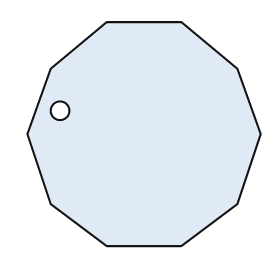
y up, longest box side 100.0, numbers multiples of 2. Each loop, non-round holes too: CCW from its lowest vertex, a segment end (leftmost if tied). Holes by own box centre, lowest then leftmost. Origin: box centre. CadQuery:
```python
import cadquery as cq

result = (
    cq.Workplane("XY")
    .moveTo(-16.0, -48.0)
    .lineTo(16.0, -48.0)
    .lineTo(40.0, -30.0)
    .lineTo(50.0, 0.0)
    .lineTo(40.0, 28.0)
    .lineTo(16.0, 48.0)
    .lineTo(-16.0, 48.0)
    .lineTo(-40.0, 28.0)
    .lineTo(-50.0, 0.0)
    .lineTo(-40.0, -30.0)
    .close()
    .moveTo(-36.0, 10.0)
    .circle(4.0)
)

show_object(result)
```